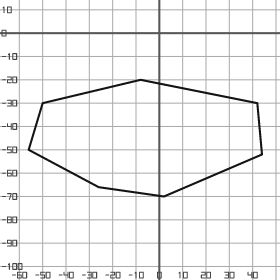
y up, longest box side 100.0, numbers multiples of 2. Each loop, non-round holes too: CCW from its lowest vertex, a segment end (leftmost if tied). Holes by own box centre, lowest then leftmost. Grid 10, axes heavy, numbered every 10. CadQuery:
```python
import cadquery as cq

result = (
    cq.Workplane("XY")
    .moveTo(2.0, -70.0)
    .lineTo(44.0, -52.0)
    .lineTo(42.0, -30.0)
    .lineTo(-8.0, -20.0)
    .lineTo(-50.0, -30.0)
    .lineTo(-56.0, -50.0)
    .lineTo(-26.0, -66.0)
    .close()
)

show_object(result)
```